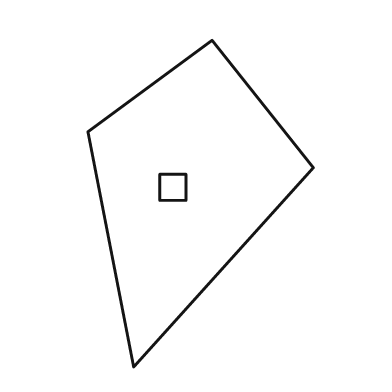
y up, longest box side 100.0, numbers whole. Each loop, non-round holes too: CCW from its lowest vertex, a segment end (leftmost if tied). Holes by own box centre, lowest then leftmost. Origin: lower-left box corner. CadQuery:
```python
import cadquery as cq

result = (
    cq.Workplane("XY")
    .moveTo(14.0, 0.0)
    .lineTo(69.0, 61.0)
    .lineTo(38.0, 100.0)
    .lineTo(0.0, 72.0)
    .close()
    .moveTo(22.0, 51.0)
    .lineTo(30.0, 51.0)
    .lineTo(30.0, 59.0)
    .lineTo(22.0, 59.0)
    .close()
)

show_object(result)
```